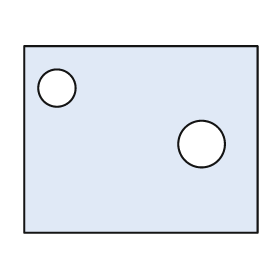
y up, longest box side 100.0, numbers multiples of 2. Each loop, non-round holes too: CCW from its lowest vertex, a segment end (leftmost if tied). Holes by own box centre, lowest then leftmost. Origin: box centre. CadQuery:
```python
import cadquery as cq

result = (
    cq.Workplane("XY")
    .moveTo(-50.0, -40.0)
    .lineTo(50.0, -40.0)
    .lineTo(50.0, 40.0)
    .lineTo(-50.0, 40.0)
    .close()
    .moveTo(26.0, -2.0)
    .circle(10.0)
    .moveTo(-36.0, 22.0)
    .circle(8.0)
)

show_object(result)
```